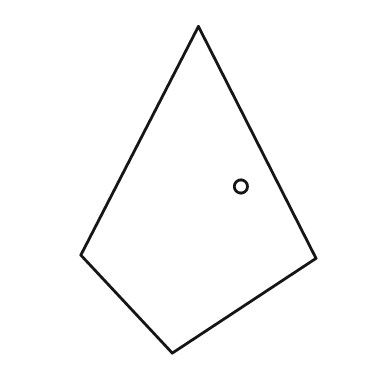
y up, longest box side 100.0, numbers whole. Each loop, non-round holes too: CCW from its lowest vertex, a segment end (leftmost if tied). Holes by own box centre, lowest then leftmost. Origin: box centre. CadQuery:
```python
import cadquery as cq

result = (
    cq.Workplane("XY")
    .moveTo(-8.0, -50.0)
    .lineTo(36.0, -21.0)
    .lineTo(0.0, 50.0)
    .lineTo(-36.0, -20.0)
    .close()
    .moveTo(13.0, 1.0)
    .circle(2.0)
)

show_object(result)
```